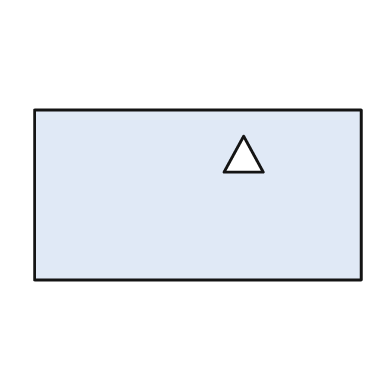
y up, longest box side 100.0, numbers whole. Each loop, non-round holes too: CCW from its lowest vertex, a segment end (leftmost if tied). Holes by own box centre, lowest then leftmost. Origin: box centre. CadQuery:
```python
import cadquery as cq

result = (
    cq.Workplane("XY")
    .moveTo(-50.0, -26.0)
    .lineTo(50.0, -26.0)
    .lineTo(50.0, 26.0)
    .lineTo(-50.0, 26.0)
    .close()
    .moveTo(8.0, 7.0)
    .lineTo(20.0, 7.0)
    .lineTo(14.0, 18.0)
    .close()
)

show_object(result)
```